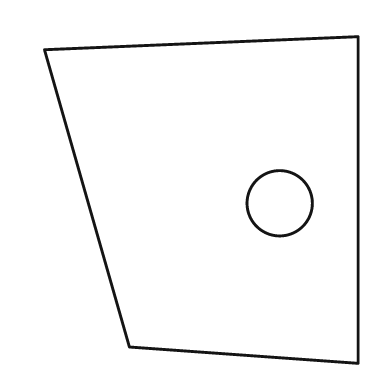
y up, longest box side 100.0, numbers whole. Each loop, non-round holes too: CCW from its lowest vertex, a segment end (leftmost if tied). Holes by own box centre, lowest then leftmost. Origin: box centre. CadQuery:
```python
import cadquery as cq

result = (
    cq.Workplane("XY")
    .moveTo(48.0, -50.0)
    .lineTo(48.0, 50.0)
    .lineTo(-48.0, 46.0)
    .lineTo(-22.0, -45.0)
    .close()
    .moveTo(24.0, -1.0)
    .circle(10.0)
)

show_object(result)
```